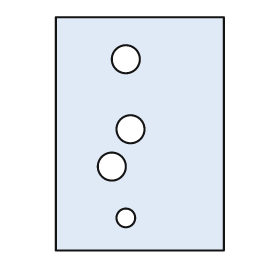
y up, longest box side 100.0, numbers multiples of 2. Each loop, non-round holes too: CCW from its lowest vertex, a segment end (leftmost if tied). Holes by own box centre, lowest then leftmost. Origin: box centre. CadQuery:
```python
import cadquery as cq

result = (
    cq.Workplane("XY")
    .moveTo(-36.0, -50.0)
    .lineTo(36.0, -50.0)
    .lineTo(36.0, 50.0)
    .lineTo(-36.0, 50.0)
    .close()
    .moveTo(-6.0, -36.0)
    .circle(4.0)
    .moveTo(-12.0, -14.0)
    .circle(6.0)
    .moveTo(-4.0, 2.0)
    .circle(6.0)
    .moveTo(-6.0, 32.0)
    .circle(6.0)
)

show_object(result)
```